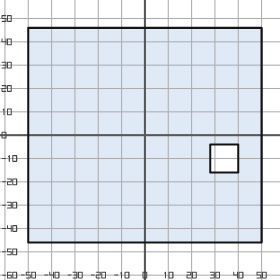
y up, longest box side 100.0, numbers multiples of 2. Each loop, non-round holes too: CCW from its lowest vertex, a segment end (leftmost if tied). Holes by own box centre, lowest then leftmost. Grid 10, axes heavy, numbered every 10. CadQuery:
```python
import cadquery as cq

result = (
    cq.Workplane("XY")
    .moveTo(-50.0, -46.0)
    .lineTo(50.0, -46.0)
    .lineTo(50.0, 46.0)
    .lineTo(-50.0, 46.0)
    .close()
    .moveTo(28.0, -16.0)
    .lineTo(40.0, -16.0)
    .lineTo(40.0, -4.0)
    .lineTo(28.0, -4.0)
    .close()
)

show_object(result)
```